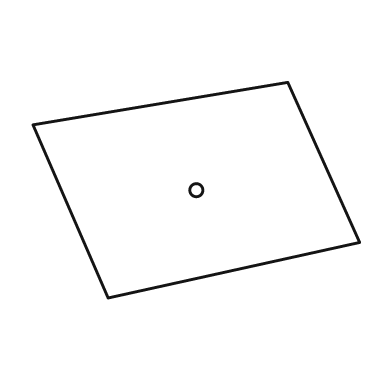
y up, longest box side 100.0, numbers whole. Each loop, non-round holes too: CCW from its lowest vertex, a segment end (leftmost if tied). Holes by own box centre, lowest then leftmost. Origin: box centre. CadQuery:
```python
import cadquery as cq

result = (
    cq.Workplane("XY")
    .moveTo(-27.0, -33.0)
    .lineTo(50.0, -16.0)
    .lineTo(28.0, 33.0)
    .lineTo(-50.0, 20.0)
    .close()
    .moveTo(0.0, 0.0)
    .circle(2.0)
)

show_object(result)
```